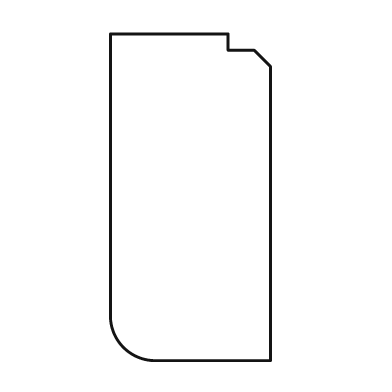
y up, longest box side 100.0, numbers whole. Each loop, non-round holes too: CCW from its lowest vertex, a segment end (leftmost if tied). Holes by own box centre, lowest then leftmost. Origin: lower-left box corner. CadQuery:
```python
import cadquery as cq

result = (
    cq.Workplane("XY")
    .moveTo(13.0, 0.0)
    .lineTo(49.0, 0.0)
    .lineTo(49.0, 90.0)
    .lineTo(44.0, 95.0)
    .lineTo(36.0, 95.0)
    .lineTo(36.0, 100.0)
    .lineTo(0.0, 100.0)
    .lineTo(0.0, 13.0)
    .threePointArc((4.0, 4.0), (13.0, 0.0))
    .close()
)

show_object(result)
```